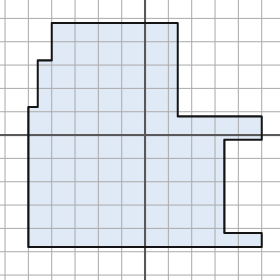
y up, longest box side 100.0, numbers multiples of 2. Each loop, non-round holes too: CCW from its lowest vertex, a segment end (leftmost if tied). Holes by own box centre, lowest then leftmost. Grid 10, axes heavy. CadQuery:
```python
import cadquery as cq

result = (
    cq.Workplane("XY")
    .moveTo(-50.0, -48.0)
    .lineTo(50.0, -48.0)
    .lineTo(50.0, -42.0)
    .lineTo(34.0, -42.0)
    .lineTo(34.0, -2.0)
    .lineTo(50.0, -2.0)
    .lineTo(50.0, 8.0)
    .lineTo(14.0, 8.0)
    .lineTo(14.0, 48.0)
    .lineTo(-40.0, 48.0)
    .lineTo(-40.0, 32.0)
    .lineTo(-46.0, 32.0)
    .lineTo(-46.0, 12.0)
    .lineTo(-50.0, 12.0)
    .close()
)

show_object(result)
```